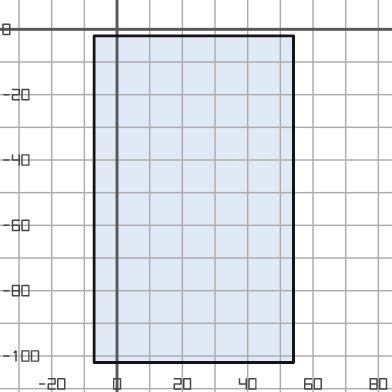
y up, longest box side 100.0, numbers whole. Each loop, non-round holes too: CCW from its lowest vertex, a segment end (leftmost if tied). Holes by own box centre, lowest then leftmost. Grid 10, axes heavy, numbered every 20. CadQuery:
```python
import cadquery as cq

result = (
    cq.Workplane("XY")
    .moveTo(-7.0, -102.0)
    .lineTo(54.0, -102.0)
    .lineTo(54.0, -2.0)
    .lineTo(-7.0, -2.0)
    .close()
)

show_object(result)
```